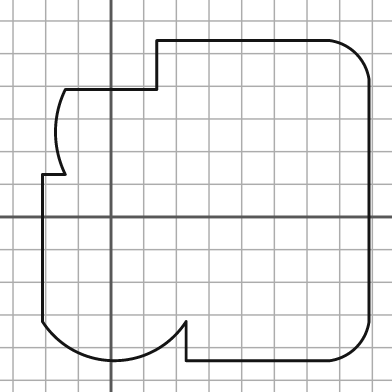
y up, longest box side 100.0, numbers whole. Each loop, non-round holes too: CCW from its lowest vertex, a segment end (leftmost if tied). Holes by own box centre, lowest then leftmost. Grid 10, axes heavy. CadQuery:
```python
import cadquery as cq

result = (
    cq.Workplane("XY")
    .moveTo(23.0, -44.0)
    .lineTo(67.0, -44.0)
    .threePointArc((75.0, -40.0), (79.0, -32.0))
    .lineTo(79.0, 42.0)
    .threePointArc((75.0, 50.0), (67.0, 54.0))
    .lineTo(14.0, 54.0)
    .lineTo(14.0, 39.0)
    .lineTo(-14.0, 39.0)
    .threePointArc((-17.0, 26.0), (-14.0, 13.0))
    .lineTo(-21.0, 13.0)
    .lineTo(-21.0, -32.0)
    .threePointArc((1.0, -44.0), (23.0, -32.0))
    .close()
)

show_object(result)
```